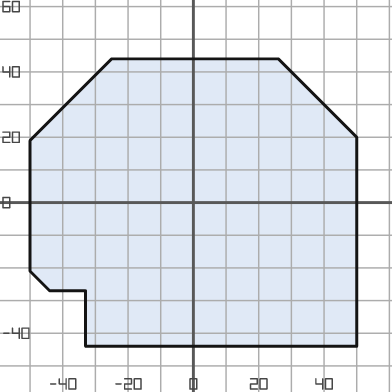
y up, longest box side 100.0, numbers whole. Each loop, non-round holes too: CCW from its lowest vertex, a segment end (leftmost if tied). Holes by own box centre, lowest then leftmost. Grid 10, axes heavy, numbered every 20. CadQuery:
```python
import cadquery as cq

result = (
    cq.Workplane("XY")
    .moveTo(-33.0, -44.0)
    .lineTo(50.0, -44.0)
    .lineTo(50.0, 20.0)
    .lineTo(26.0, 44.0)
    .lineTo(-25.0, 44.0)
    .lineTo(-50.0, 19.0)
    .lineTo(-50.0, -21.0)
    .lineTo(-44.0, -27.0)
    .lineTo(-33.0, -27.0)
    .close()
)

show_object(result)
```